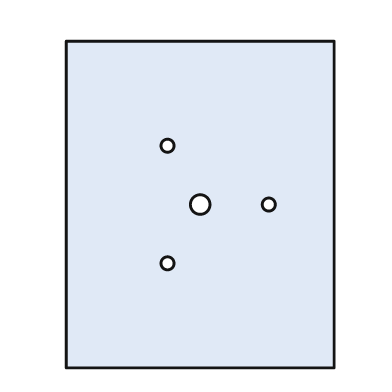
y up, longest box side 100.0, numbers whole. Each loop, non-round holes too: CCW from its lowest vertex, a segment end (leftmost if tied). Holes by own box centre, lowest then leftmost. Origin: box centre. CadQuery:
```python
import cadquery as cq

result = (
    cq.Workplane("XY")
    .moveTo(-41.0, -50.0)
    .lineTo(41.0, -50.0)
    .lineTo(41.0, 50.0)
    .lineTo(-41.0, 50.0)
    .close()
    .moveTo(-10.0, -18.0)
    .circle(2.0)
    .moveTo(0.0, 0.0)
    .circle(3.0)
    .moveTo(21.0, 0.0)
    .circle(2.0)
    .moveTo(-10.0, 18.0)
    .circle(2.0)
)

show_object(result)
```